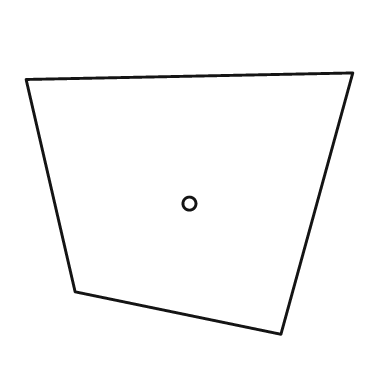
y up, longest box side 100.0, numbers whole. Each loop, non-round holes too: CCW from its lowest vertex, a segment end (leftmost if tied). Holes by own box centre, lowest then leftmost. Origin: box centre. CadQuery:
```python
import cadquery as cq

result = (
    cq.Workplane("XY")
    .moveTo(28.0, -40.0)
    .lineTo(50.0, 40.0)
    .lineTo(-50.0, 38.0)
    .lineTo(-35.0, -27.0)
    .close()
    .moveTo(0.0, 0.0)
    .circle(2.0)
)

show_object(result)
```